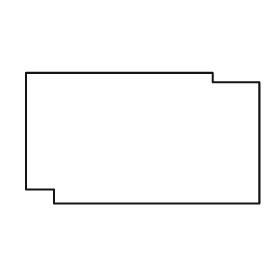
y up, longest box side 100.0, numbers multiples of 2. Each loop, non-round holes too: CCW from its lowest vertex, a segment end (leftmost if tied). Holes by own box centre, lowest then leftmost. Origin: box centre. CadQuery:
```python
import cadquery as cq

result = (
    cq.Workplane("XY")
    .moveTo(-38.0, -28.0)
    .lineTo(50.0, -28.0)
    .lineTo(50.0, 24.0)
    .lineTo(30.0, 24.0)
    .lineTo(30.0, 28.0)
    .lineTo(-50.0, 28.0)
    .lineTo(-50.0, -22.0)
    .lineTo(-38.0, -22.0)
    .close()
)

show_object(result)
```